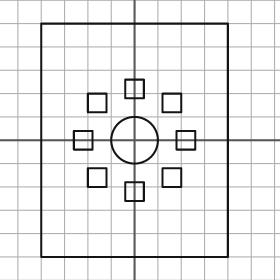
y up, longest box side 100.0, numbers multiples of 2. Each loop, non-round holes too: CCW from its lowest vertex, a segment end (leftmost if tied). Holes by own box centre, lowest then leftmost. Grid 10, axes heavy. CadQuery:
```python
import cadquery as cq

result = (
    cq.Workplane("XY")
    .moveTo(-40.0, -50.0)
    .lineTo(40.0, -50.0)
    .lineTo(40.0, 50.0)
    .lineTo(-40.0, 50.0)
    .close()
    .moveTo(-4.0, -26.0)
    .lineTo(4.0, -26.0)
    .lineTo(4.0, -18.0)
    .lineTo(-4.0, -18.0)
    .close()
    .moveTo(-20.0, -20.0)
    .lineTo(-12.0, -20.0)
    .lineTo(-12.0, -12.0)
    .lineTo(-20.0, -12.0)
    .close()
    .moveTo(12.0, -20.0)
    .lineTo(20.0, -20.0)
    .lineTo(20.0, -12.0)
    .lineTo(12.0, -12.0)
    .close()
    .moveTo(-26.0, -4.0)
    .lineTo(-18.0, -4.0)
    .lineTo(-18.0, 4.0)
    .lineTo(-26.0, 4.0)
    .close()
    .moveTo(0.0, 0.0)
    .circle(10.0)
    .moveTo(18.0, -4.0)
    .lineTo(26.0, -4.0)
    .lineTo(26.0, 4.0)
    .lineTo(18.0, 4.0)
    .close()
    .moveTo(-20.0, 12.0)
    .lineTo(-12.0, 12.0)
    .lineTo(-12.0, 20.0)
    .lineTo(-20.0, 20.0)
    .close()
    .moveTo(12.0, 12.0)
    .lineTo(20.0, 12.0)
    .lineTo(20.0, 20.0)
    .lineTo(12.0, 20.0)
    .close()
    .moveTo(-4.0, 18.0)
    .lineTo(4.0, 18.0)
    .lineTo(4.0, 26.0)
    .lineTo(-4.0, 26.0)
    .close()
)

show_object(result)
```